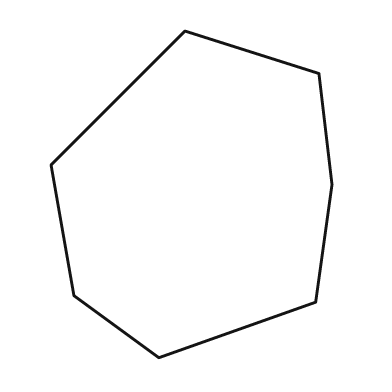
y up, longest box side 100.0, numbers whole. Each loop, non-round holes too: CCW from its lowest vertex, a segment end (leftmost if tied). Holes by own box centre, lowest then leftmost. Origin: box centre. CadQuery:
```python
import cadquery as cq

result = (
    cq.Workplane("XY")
    .moveTo(-10.0, -50.0)
    .lineTo(38.0, -33.0)
    .lineTo(43.0, 3.0)
    .lineTo(39.0, 37.0)
    .lineTo(-2.0, 50.0)
    .lineTo(-43.0, 9.0)
    .lineTo(-36.0, -31.0)
    .close()
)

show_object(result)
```